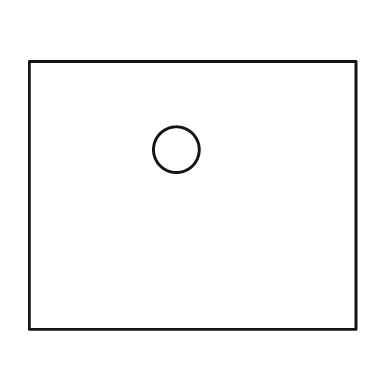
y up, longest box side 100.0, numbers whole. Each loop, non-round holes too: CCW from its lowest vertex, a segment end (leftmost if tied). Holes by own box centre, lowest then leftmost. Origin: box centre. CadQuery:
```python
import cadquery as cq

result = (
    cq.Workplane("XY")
    .moveTo(-50.0, -41.0)
    .lineTo(50.0, -41.0)
    .lineTo(50.0, 41.0)
    .lineTo(-50.0, 41.0)
    .close()
    .moveTo(-5.0, 14.0)
    .circle(7.0)
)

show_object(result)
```